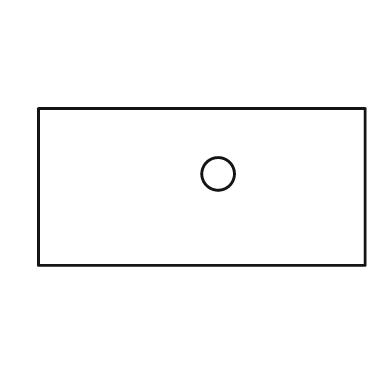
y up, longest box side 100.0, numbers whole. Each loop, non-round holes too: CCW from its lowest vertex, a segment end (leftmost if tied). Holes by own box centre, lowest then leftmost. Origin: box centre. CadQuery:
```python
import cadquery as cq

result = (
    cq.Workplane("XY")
    .moveTo(-50.0, -24.0)
    .lineTo(50.0, -24.0)
    .lineTo(50.0, 24.0)
    .lineTo(-50.0, 24.0)
    .close()
    .moveTo(5.0, 4.0)
    .circle(5.0)
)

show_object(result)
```